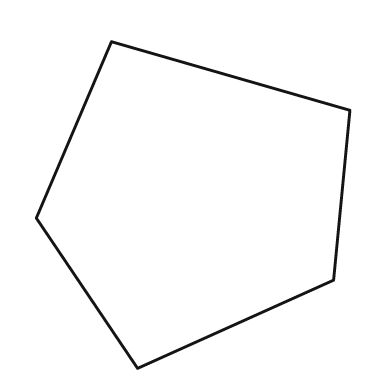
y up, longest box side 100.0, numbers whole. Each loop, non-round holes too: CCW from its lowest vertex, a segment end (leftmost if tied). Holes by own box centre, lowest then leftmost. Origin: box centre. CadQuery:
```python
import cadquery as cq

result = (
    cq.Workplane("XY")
    .moveTo(-17.0, -50.0)
    .lineTo(43.0, -23.0)
    .lineTo(48.0, 29.0)
    .lineTo(-25.0, 50.0)
    .lineTo(-48.0, -4.0)
    .close()
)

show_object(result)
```